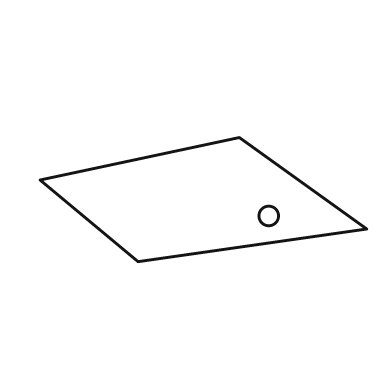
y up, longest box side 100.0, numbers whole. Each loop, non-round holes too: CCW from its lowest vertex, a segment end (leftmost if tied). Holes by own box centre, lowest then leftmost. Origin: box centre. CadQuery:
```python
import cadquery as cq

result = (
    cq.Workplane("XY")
    .moveTo(-20.0, -19.0)
    .lineTo(50.0, -9.0)
    .lineTo(11.0, 19.0)
    .lineTo(-50.0, 6.0)
    .close()
    .moveTo(20.0, -5.0)
    .circle(3.0)
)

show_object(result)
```